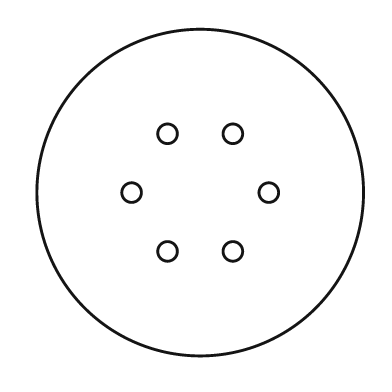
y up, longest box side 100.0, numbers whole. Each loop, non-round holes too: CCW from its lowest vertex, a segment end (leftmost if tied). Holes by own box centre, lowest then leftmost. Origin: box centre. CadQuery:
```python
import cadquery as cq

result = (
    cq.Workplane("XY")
    .moveTo(0.0, 0.0)
    .circle(50.0)
    .moveTo(-10.0, -18.0)
    .circle(3.0)
    .moveTo(10.0, -18.0)
    .circle(3.0)
    .moveTo(-21.0, 0.0)
    .circle(3.0)
    .moveTo(21.0, 0.0)
    .circle(3.0)
    .moveTo(-10.0, 18.0)
    .circle(3.0)
    .moveTo(10.0, 18.0)
    .circle(3.0)
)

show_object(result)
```